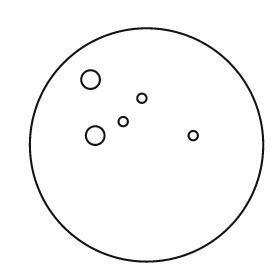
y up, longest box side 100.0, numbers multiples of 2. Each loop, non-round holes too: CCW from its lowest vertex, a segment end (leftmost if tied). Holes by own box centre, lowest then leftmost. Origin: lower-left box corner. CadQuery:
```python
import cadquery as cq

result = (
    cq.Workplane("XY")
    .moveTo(50.0, 50.0)
    .circle(50.0)
    .moveTo(28.0, 54.0)
    .circle(4.0)
    .moveTo(70.0, 54.0)
    .circle(2.0)
    .moveTo(40.0, 60.0)
    .circle(2.0)
    .moveTo(48.0, 70.0)
    .circle(2.0)
    .moveTo(26.0, 78.0)
    .circle(4.0)
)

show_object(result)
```